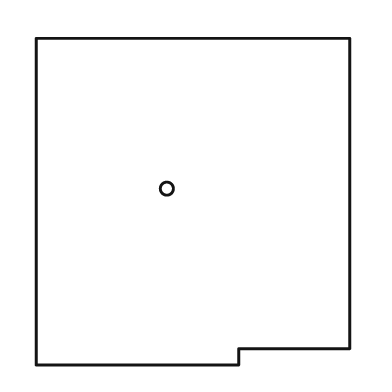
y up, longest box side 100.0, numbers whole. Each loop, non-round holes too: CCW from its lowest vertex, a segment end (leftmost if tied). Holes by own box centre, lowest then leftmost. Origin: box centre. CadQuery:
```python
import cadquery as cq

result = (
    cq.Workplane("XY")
    .moveTo(-48.0, -50.0)
    .lineTo(14.0, -50.0)
    .lineTo(14.0, -45.0)
    .lineTo(48.0, -45.0)
    .lineTo(48.0, 50.0)
    .lineTo(-48.0, 50.0)
    .close()
    .moveTo(-8.0, 4.0)
    .circle(2.0)
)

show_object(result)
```